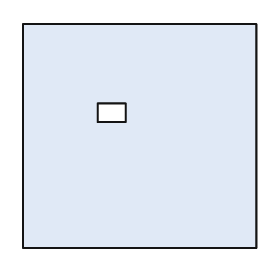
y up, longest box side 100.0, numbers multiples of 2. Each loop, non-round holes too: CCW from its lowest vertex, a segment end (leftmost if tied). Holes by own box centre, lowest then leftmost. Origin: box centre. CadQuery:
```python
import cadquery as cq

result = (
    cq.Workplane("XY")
    .moveTo(-50.0, -48.0)
    .lineTo(50.0, -48.0)
    .lineTo(50.0, 48.0)
    .lineTo(-50.0, 48.0)
    .close()
    .moveTo(-18.0, 6.0)
    .lineTo(-6.0, 6.0)
    .lineTo(-6.0, 14.0)
    .lineTo(-18.0, 14.0)
    .close()
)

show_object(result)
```